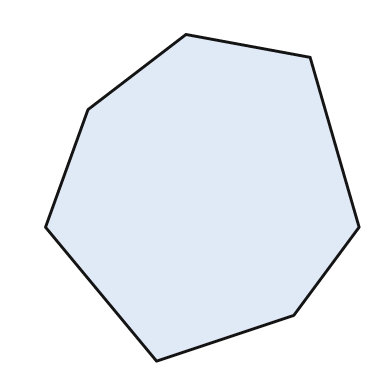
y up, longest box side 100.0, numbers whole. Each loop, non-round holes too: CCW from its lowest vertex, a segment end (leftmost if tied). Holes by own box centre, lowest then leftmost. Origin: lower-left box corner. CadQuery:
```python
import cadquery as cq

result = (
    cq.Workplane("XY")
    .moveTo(34.0, 0.0)
    .lineTo(76.0, 14.0)
    .lineTo(96.0, 41.0)
    .lineTo(81.0, 93.0)
    .lineTo(43.0, 100.0)
    .lineTo(13.0, 77.0)
    .lineTo(0.0, 41.0)
    .close()
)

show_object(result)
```